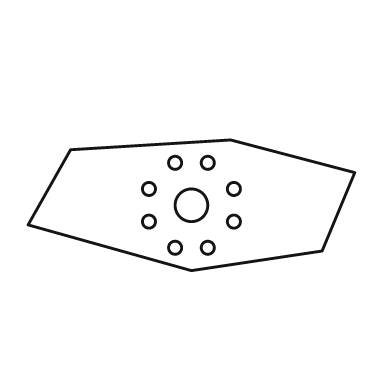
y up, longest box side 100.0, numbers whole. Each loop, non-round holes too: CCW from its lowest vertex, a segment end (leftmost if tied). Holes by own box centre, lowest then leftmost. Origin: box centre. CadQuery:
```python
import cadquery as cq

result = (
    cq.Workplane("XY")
    .moveTo(0.0, -20.0)
    .lineTo(40.0, -14.0)
    .lineTo(50.0, 10.0)
    .lineTo(12.0, 20.0)
    .lineTo(-37.0, 17.0)
    .lineTo(-50.0, -6.0)
    .close()
    .moveTo(-5.0, -13.0)
    .circle(2.0)
    .moveTo(5.0, -13.0)
    .circle(2.0)
    .moveTo(-13.0, -5.0)
    .circle(2.0)
    .moveTo(13.0, -5.0)
    .circle(2.0)
    .moveTo(0.0, 0.0)
    .circle(5.0)
    .moveTo(-13.0, 5.0)
    .circle(2.0)
    .moveTo(13.0, 5.0)
    .circle(2.0)
    .moveTo(-5.0, 13.0)
    .circle(2.0)
    .moveTo(5.0, 13.0)
    .circle(2.0)
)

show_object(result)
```